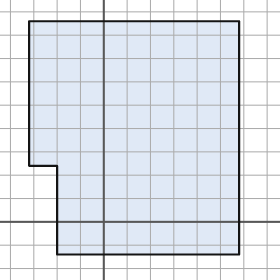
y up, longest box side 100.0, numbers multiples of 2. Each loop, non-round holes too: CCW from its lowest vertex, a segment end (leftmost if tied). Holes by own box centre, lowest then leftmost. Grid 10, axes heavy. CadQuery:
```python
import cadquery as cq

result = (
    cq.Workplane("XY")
    .moveTo(-20.0, -14.0)
    .lineTo(58.0, -14.0)
    .lineTo(58.0, 86.0)
    .lineTo(-32.0, 86.0)
    .lineTo(-32.0, 24.0)
    .lineTo(-20.0, 24.0)
    .close()
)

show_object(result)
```